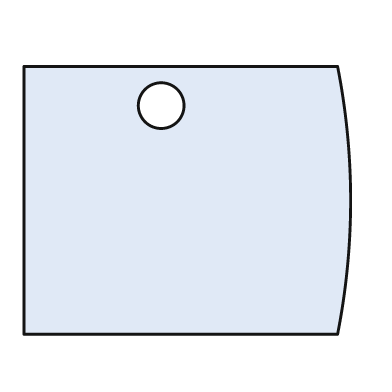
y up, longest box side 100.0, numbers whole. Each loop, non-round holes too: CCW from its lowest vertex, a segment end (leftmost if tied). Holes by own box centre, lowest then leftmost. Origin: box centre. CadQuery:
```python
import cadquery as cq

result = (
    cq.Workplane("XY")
    .moveTo(-50.0, -41.0)
    .lineTo(46.0, -41.0)
    .threePointArc((50.0, 0.0), (46.0, 41.0))
    .lineTo(-50.0, 41.0)
    .close()
    .moveTo(-8.0, 29.0)
    .circle(7.0)
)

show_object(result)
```